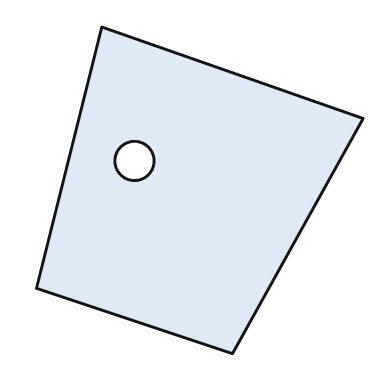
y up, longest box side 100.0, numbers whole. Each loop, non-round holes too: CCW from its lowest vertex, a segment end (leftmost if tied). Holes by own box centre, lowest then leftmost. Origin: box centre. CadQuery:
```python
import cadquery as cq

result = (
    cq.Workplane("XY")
    .moveTo(10.0, -50.0)
    .lineTo(50.0, 22.0)
    .lineTo(-30.0, 50.0)
    .lineTo(-50.0, -30.0)
    .close()
    .moveTo(-20.0, 9.0)
    .circle(6.0)
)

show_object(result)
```